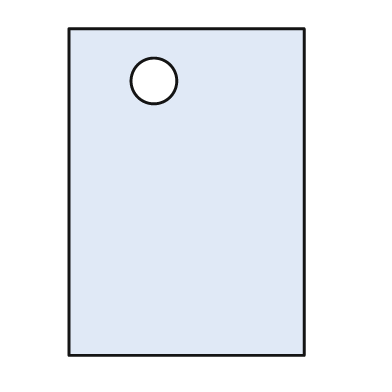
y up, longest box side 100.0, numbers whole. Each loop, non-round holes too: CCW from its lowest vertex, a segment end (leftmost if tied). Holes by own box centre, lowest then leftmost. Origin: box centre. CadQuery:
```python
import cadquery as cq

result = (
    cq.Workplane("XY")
    .moveTo(-36.0, -50.0)
    .lineTo(36.0, -50.0)
    .lineTo(36.0, 50.0)
    .lineTo(-36.0, 50.0)
    .close()
    .moveTo(-10.0, 34.0)
    .circle(7.0)
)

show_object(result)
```